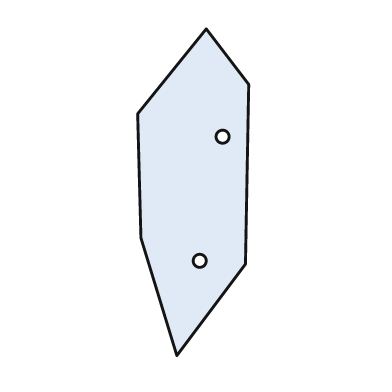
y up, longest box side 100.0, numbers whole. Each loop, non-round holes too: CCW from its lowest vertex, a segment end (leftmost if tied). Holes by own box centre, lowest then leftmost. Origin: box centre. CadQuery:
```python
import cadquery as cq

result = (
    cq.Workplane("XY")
    .moveTo(-5.0, -50.0)
    .lineTo(16.0, -22.0)
    .lineTo(17.0, 33.0)
    .lineTo(4.0, 50.0)
    .lineTo(-17.0, 24.0)
    .lineTo(-16.0, -14.0)
    .close()
    .moveTo(2.0, -21.0)
    .circle(2.0)
    .moveTo(9.0, 17.0)
    .circle(2.0)
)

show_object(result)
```